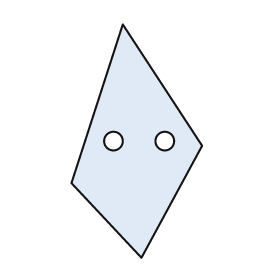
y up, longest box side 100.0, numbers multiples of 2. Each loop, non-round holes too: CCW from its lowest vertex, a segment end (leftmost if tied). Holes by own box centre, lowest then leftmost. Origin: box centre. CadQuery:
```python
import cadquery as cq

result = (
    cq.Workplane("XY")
    .moveTo(2.0, -50.0)
    .lineTo(28.0, -2.0)
    .lineTo(-6.0, 50.0)
    .lineTo(-28.0, -18.0)
    .close()
    .moveTo(-10.0, 0.0)
    .circle(4.0)
    .moveTo(12.0, 0.0)
    .circle(4.0)
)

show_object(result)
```